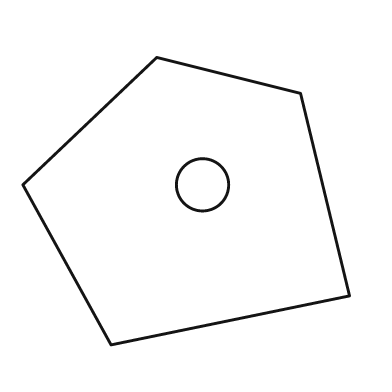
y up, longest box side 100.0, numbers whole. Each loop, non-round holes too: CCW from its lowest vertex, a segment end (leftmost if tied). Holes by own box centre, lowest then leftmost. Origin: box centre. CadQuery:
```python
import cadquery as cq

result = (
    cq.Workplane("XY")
    .moveTo(-23.0, -44.0)
    .lineTo(50.0, -29.0)
    .lineTo(35.0, 33.0)
    .lineTo(-9.0, 44.0)
    .lineTo(-50.0, 5.0)
    .close()
    .moveTo(5.0, 5.0)
    .circle(8.0)
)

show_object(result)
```